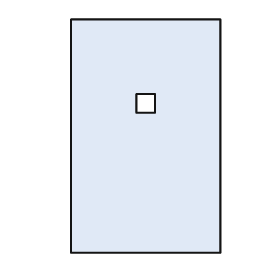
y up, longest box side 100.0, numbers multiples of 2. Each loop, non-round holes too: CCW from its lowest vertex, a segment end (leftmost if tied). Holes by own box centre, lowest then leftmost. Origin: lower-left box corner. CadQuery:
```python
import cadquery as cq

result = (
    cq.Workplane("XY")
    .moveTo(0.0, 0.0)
    .lineTo(64.0, 0.0)
    .lineTo(64.0, 100.0)
    .lineTo(0.0, 100.0)
    .close()
    .moveTo(28.0, 60.0)
    .lineTo(36.0, 60.0)
    .lineTo(36.0, 68.0)
    .lineTo(28.0, 68.0)
    .close()
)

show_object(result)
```